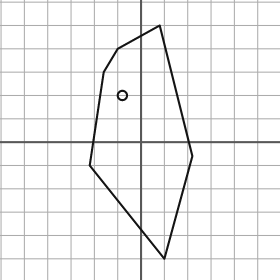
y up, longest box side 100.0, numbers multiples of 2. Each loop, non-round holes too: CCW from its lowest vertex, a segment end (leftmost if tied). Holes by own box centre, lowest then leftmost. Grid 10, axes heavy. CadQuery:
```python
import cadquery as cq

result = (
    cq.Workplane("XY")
    .moveTo(10.0, -50.0)
    .lineTo(22.0, -6.0)
    .lineTo(8.0, 50.0)
    .lineTo(-10.0, 40.0)
    .lineTo(-16.0, 30.0)
    .lineTo(-22.0, -10.0)
    .close()
    .moveTo(-8.0, 20.0)
    .circle(2.0)
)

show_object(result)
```